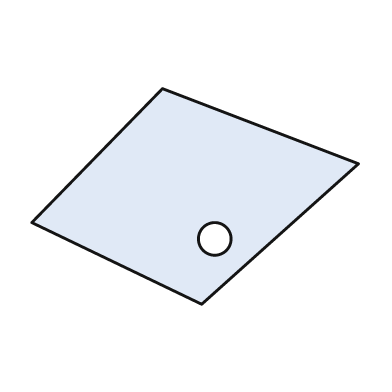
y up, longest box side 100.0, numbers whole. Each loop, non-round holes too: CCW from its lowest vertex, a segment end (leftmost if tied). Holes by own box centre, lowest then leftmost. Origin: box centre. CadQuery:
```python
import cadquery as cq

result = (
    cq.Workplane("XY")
    .moveTo(2.0, -33.0)
    .lineTo(50.0, 10.0)
    .lineTo(-10.0, 33.0)
    .lineTo(-50.0, -8.0)
    .close()
    .moveTo(6.0, -13.0)
    .circle(5.0)
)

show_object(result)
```